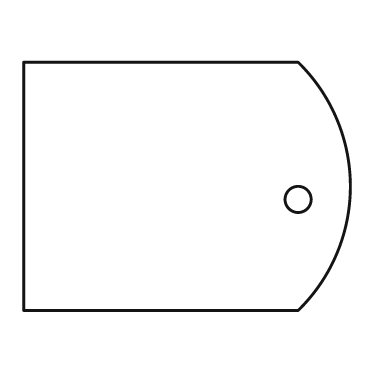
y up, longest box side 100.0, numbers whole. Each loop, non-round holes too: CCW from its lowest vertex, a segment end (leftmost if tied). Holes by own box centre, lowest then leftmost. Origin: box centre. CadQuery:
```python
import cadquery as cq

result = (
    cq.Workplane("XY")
    .moveTo(-50.0, -38.0)
    .lineTo(34.0, -38.0)
    .threePointArc((50.0, 0.0), (34.0, 38.0))
    .lineTo(-50.0, 38.0)
    .close()
    .moveTo(34.0, -4.0)
    .circle(4.0)
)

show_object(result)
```